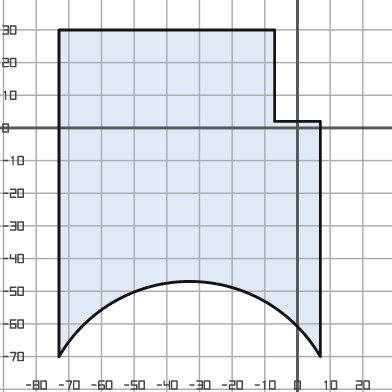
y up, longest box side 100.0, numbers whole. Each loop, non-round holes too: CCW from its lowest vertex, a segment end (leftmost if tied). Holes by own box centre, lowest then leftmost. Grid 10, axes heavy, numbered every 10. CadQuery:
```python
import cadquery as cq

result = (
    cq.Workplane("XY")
    .moveTo(-73.0, -70.0)
    .threePointArc((-33.0, -47.0), (7.0, -70.0))
    .lineTo(7.0, 2.0)
    .lineTo(-7.0, 2.0)
    .lineTo(-7.0, 30.0)
    .lineTo(-73.0, 30.0)
    .close()
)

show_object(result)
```